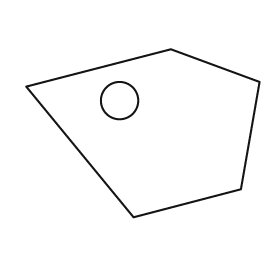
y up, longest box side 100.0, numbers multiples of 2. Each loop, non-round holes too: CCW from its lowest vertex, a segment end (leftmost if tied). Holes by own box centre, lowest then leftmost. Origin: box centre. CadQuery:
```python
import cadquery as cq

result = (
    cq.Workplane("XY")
    .moveTo(-4.0, -36.0)
    .lineTo(42.0, -24.0)
    .lineTo(50.0, 22.0)
    .lineTo(12.0, 36.0)
    .lineTo(-50.0, 20.0)
    .close()
    .moveTo(-10.0, 14.0)
    .circle(8.0)
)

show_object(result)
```